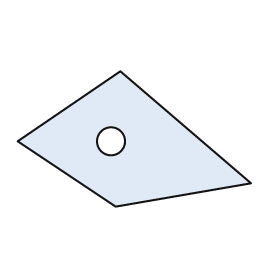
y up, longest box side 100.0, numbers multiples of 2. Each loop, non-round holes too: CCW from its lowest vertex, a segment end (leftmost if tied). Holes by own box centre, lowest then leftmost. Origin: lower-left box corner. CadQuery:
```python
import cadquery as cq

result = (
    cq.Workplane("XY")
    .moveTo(42.0, 0.0)
    .lineTo(100.0, 10.0)
    .lineTo(44.0, 58.0)
    .lineTo(0.0, 28.0)
    .close()
    .moveTo(40.0, 28.0)
    .circle(6.0)
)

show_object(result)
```